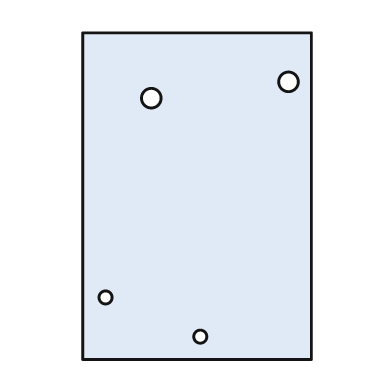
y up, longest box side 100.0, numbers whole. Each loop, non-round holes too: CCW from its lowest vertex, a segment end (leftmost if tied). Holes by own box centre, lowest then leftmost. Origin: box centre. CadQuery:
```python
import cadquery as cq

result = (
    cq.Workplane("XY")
    .moveTo(-35.0, -50.0)
    .lineTo(35.0, -50.0)
    .lineTo(35.0, 50.0)
    .lineTo(-35.0, 50.0)
    .close()
    .moveTo(1.0, -43.0)
    .circle(2.0)
    .moveTo(-28.0, -31.0)
    .circle(2.0)
    .moveTo(-14.0, 30.0)
    .circle(3.0)
    .moveTo(28.0, 35.0)
    .circle(3.0)
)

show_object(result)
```